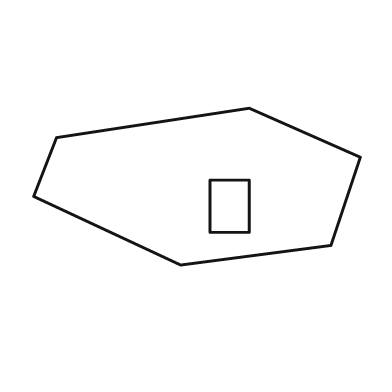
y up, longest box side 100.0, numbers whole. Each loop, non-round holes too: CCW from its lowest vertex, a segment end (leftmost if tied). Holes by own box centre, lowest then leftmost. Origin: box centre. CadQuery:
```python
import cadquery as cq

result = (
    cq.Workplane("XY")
    .moveTo(-5.0, -24.0)
    .lineTo(41.0, -18.0)
    .lineTo(50.0, 9.0)
    .lineTo(16.0, 24.0)
    .lineTo(-43.0, 15.0)
    .lineTo(-50.0, -3.0)
    .close()
    .moveTo(4.0, -14.0)
    .lineTo(16.0, -14.0)
    .lineTo(16.0, 2.0)
    .lineTo(4.0, 2.0)
    .close()
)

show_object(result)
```